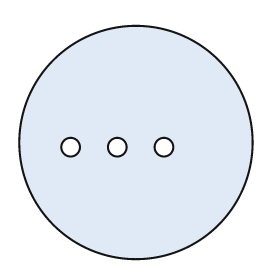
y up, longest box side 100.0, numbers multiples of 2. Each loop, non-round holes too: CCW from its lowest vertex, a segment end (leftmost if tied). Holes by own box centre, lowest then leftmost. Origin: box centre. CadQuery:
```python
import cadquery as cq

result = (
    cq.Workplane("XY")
    .moveTo(0.0, 0.0)
    .circle(50.0)
    .moveTo(-28.0, -2.0)
    .circle(4.0)
    .moveTo(-8.0, -2.0)
    .circle(4.0)
    .moveTo(12.0, -2.0)
    .circle(4.0)
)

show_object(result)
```